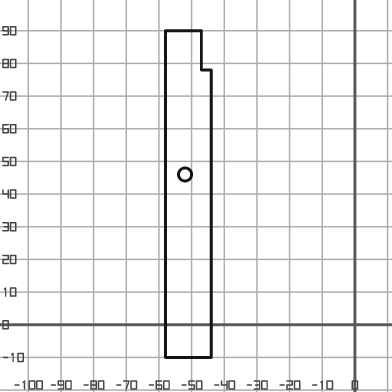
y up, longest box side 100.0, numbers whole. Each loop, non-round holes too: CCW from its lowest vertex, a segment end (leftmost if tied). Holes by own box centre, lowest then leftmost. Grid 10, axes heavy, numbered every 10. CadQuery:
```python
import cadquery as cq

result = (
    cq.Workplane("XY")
    .moveTo(-58.0, -10.0)
    .lineTo(-44.0, -10.0)
    .lineTo(-44.0, 78.0)
    .lineTo(-47.0, 78.0)
    .lineTo(-47.0, 90.0)
    .lineTo(-58.0, 90.0)
    .close()
    .moveTo(-52.0, 46.0)
    .circle(2.0)
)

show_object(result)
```